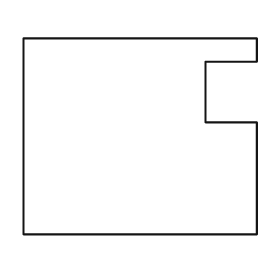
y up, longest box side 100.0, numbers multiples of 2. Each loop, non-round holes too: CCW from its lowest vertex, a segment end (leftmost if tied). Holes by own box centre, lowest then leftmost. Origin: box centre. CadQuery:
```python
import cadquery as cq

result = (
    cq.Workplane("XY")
    .moveTo(-50.0, -42.0)
    .lineTo(50.0, -42.0)
    .lineTo(50.0, 6.0)
    .lineTo(28.0, 6.0)
    .lineTo(28.0, 32.0)
    .lineTo(50.0, 32.0)
    .lineTo(50.0, 42.0)
    .lineTo(-50.0, 42.0)
    .close()
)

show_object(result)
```